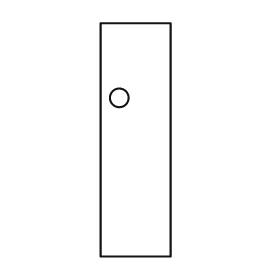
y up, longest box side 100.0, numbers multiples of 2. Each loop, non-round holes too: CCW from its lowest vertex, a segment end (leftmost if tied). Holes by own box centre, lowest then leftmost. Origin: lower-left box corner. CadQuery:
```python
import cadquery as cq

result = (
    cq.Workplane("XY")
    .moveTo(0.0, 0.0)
    .lineTo(30.0, 0.0)
    .lineTo(30.0, 100.0)
    .lineTo(0.0, 100.0)
    .close()
    .moveTo(8.0, 68.0)
    .circle(4.0)
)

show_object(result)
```